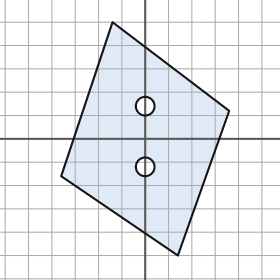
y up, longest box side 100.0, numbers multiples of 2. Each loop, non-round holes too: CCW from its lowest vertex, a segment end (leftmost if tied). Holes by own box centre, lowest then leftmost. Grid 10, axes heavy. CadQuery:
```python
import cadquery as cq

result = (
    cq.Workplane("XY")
    .moveTo(14.0, -50.0)
    .lineTo(36.0, 12.0)
    .lineTo(-14.0, 50.0)
    .lineTo(-36.0, -16.0)
    .close()
    .moveTo(0.0, -12.0)
    .circle(4.0)
    .moveTo(0.0, 14.0)
    .circle(4.0)
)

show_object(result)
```